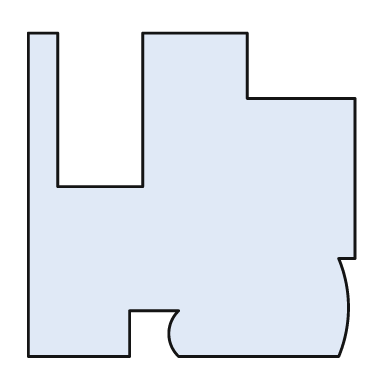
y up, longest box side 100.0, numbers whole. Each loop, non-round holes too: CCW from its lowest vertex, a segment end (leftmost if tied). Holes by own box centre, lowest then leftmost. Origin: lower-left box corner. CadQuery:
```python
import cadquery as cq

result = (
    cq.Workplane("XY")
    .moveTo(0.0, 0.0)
    .lineTo(31.0, 0.0)
    .lineTo(31.0, 14.0)
    .lineTo(46.0, 14.0)
    .threePointArc((43.0, 7.0), (46.0, 0.0))
    .lineTo(95.0, 0.0)
    .threePointArc((98.0, 15.0), (95.0, 30.0))
    .lineTo(100.0, 30.0)
    .lineTo(100.0, 79.0)
    .lineTo(67.0, 79.0)
    .lineTo(67.0, 99.0)
    .lineTo(35.0, 99.0)
    .lineTo(35.0, 52.0)
    .lineTo(9.0, 52.0)
    .lineTo(9.0, 99.0)
    .lineTo(0.0, 99.0)
    .close()
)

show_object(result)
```